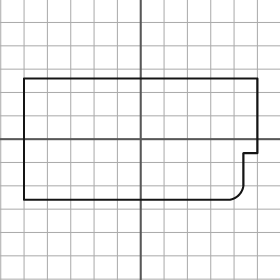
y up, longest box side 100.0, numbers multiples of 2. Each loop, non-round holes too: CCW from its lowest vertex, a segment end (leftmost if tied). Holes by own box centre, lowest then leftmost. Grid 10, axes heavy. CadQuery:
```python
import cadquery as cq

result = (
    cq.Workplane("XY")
    .moveTo(-50.0, -26.0)
    .lineTo(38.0, -26.0)
    .threePointArc((42.0, -24.0), (44.0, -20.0))
    .lineTo(44.0, -6.0)
    .lineTo(50.0, -6.0)
    .lineTo(50.0, 26.0)
    .lineTo(-50.0, 26.0)
    .close()
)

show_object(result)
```